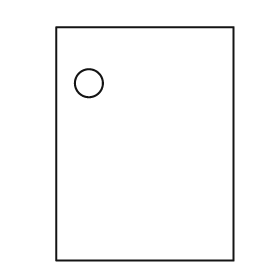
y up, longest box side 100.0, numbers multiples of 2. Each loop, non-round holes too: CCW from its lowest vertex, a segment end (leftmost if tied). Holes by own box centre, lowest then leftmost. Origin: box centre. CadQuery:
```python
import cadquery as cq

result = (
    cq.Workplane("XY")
    .moveTo(-38.0, -50.0)
    .lineTo(38.0, -50.0)
    .lineTo(38.0, 50.0)
    .lineTo(-38.0, 50.0)
    .close()
    .moveTo(-24.0, 26.0)
    .circle(6.0)
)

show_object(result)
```